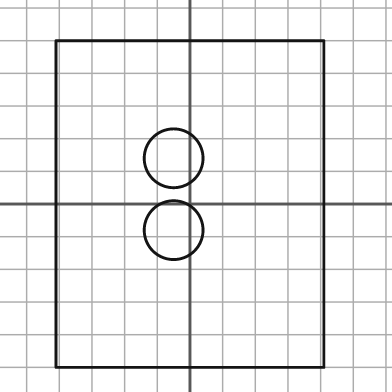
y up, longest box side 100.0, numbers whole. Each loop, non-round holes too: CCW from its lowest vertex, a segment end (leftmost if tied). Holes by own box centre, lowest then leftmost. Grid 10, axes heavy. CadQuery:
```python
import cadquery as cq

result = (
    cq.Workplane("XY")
    .moveTo(-41.0, -50.0)
    .lineTo(41.0, -50.0)
    .lineTo(41.0, 50.0)
    .lineTo(-41.0, 50.0)
    .close()
    .moveTo(-5.0, -8.0)
    .circle(9.0)
    .moveTo(-5.0, 14.0)
    .circle(9.0)
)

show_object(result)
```